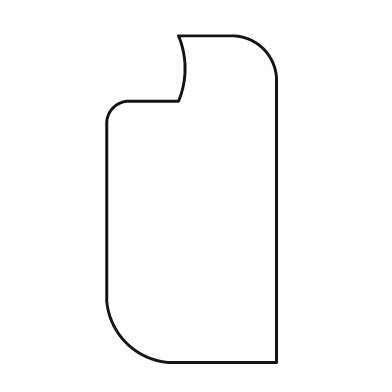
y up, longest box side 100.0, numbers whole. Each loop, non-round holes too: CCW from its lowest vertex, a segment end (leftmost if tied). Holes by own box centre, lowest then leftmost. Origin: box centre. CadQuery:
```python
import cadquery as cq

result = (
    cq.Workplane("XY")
    .moveTo(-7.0, -50.0)
    .lineTo(26.0, -50.0)
    .lineTo(26.0, 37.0)
    .threePointArc((22.0, 46.0), (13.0, 50.0))
    .lineTo(-4.0, 50.0)
    .threePointArc((-2.0, 40.0), (-4.0, 30.0))
    .lineTo(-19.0, 30.0)
    .threePointArc((-24.0, 28.0), (-26.0, 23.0))
    .lineTo(-26.0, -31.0)
    .threePointArc((-20.0, -44.0), (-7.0, -50.0))
    .close()
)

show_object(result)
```